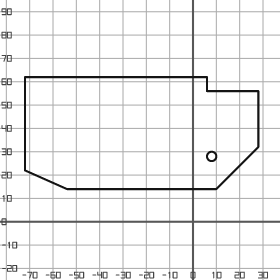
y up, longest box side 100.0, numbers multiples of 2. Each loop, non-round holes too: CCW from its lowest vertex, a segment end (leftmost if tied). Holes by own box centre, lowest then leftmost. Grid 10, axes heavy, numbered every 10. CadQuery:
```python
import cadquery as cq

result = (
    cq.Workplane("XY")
    .moveTo(-54.0, 14.0)
    .lineTo(10.0, 14.0)
    .lineTo(28.0, 32.0)
    .lineTo(28.0, 56.0)
    .lineTo(6.0, 56.0)
    .lineTo(6.0, 62.0)
    .lineTo(-72.0, 62.0)
    .lineTo(-72.0, 22.0)
    .close()
    .moveTo(8.0, 28.0)
    .circle(2.0)
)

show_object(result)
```